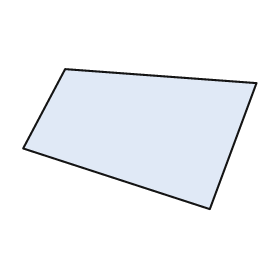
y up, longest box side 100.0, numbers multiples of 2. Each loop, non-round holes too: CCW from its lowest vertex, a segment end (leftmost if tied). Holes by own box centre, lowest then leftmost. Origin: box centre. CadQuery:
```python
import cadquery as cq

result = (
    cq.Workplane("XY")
    .moveTo(30.0, -30.0)
    .lineTo(50.0, 24.0)
    .lineTo(-32.0, 30.0)
    .lineTo(-50.0, -4.0)
    .close()
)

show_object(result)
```